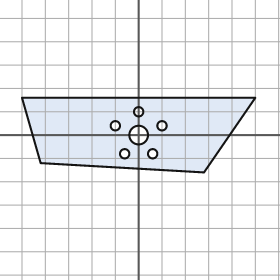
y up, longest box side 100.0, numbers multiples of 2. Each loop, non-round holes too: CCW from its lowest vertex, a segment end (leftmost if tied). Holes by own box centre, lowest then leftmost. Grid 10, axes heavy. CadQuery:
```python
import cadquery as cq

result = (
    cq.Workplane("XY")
    .moveTo(28.0, -16.0)
    .lineTo(50.0, 16.0)
    .lineTo(-50.0, 16.0)
    .lineTo(-42.0, -12.0)
    .close()
    .moveTo(-6.0, -8.0)
    .circle(2.0)
    .moveTo(6.0, -8.0)
    .circle(2.0)
    .moveTo(0.0, 0.0)
    .circle(4.0)
    .moveTo(-10.0, 4.0)
    .circle(2.0)
    .moveTo(10.0, 4.0)
    .circle(2.0)
    .moveTo(0.0, 10.0)
    .circle(2.0)
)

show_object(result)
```